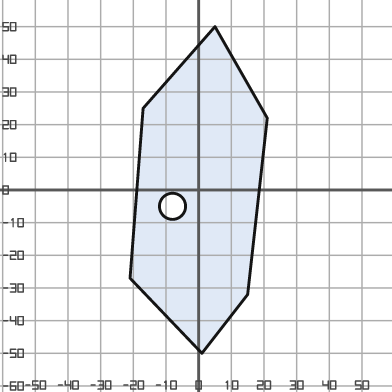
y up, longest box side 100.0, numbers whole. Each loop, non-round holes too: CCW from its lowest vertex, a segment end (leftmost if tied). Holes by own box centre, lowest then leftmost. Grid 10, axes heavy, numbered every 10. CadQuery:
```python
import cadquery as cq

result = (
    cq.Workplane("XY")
    .moveTo(1.0, -50.0)
    .lineTo(15.0, -32.0)
    .lineTo(21.0, 22.0)
    .lineTo(5.0, 50.0)
    .lineTo(-17.0, 25.0)
    .lineTo(-21.0, -27.0)
    .close()
    .moveTo(-8.0, -5.0)
    .circle(4.0)
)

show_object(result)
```